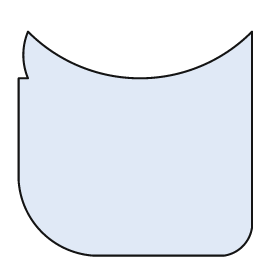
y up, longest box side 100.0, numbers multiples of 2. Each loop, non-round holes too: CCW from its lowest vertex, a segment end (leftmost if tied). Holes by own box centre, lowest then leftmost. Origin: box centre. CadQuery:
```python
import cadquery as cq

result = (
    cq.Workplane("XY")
    .moveTo(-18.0, -48.0)
    .lineTo(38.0, -48.0)
    .threePointArc((46.0, -44.0), (50.0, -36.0))
    .lineTo(50.0, 48.0)
    .threePointArc((2.0, 28.0), (-46.0, 48.0))
    .threePointArc((-48.0, 38.0), (-46.0, 28.0))
    .lineTo(-50.0, 28.0)
    .lineTo(-50.0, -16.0)
    .threePointArc((-40.0, -38.0), (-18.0, -48.0))
    .close()
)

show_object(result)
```